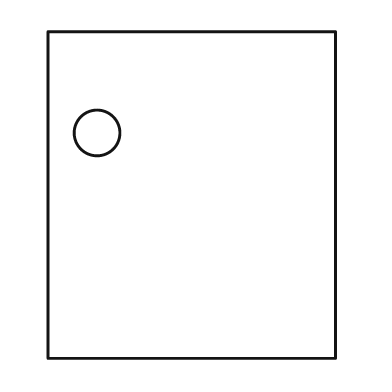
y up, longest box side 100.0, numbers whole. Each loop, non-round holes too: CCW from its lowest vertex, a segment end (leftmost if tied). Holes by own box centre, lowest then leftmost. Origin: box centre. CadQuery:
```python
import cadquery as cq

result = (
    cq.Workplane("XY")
    .moveTo(-44.0, -50.0)
    .lineTo(44.0, -50.0)
    .lineTo(44.0, 50.0)
    .lineTo(-44.0, 50.0)
    .close()
    .moveTo(-29.0, 19.0)
    .circle(7.0)
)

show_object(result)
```